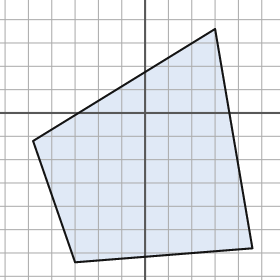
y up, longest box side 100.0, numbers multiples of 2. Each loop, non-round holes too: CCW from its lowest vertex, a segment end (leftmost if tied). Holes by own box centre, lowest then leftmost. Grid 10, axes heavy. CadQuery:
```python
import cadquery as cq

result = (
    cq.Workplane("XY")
    .moveTo(-30.0, -64.0)
    .lineTo(46.0, -58.0)
    .lineTo(30.0, 36.0)
    .lineTo(-48.0, -12.0)
    .close()
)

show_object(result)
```